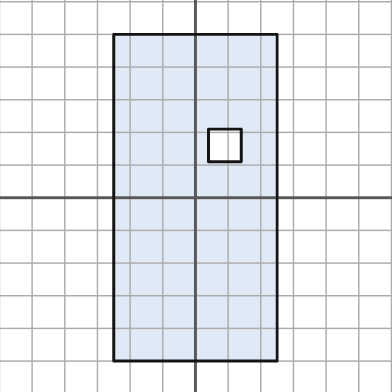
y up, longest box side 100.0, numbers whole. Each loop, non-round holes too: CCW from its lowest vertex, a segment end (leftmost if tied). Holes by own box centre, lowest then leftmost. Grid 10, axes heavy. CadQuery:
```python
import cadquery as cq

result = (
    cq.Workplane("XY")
    .moveTo(-25.0, -50.0)
    .lineTo(25.0, -50.0)
    .lineTo(25.0, 50.0)
    .lineTo(-25.0, 50.0)
    .close()
    .moveTo(4.0, 11.0)
    .lineTo(14.0, 11.0)
    .lineTo(14.0, 21.0)
    .lineTo(4.0, 21.0)
    .close()
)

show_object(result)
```